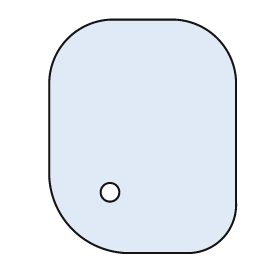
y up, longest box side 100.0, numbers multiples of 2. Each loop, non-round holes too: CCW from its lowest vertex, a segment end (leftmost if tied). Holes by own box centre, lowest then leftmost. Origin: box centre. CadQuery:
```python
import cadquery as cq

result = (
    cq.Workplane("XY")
    .moveTo(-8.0, -50.0)
    .lineTo(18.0, -50.0)
    .threePointArc((34.0, -44.0), (40.0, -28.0))
    .lineTo(40.0, 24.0)
    .threePointArc((32.0, 42.0), (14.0, 50.0))
    .lineTo(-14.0, 50.0)
    .threePointArc((-32.0, 42.0), (-40.0, 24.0))
    .lineTo(-40.0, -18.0)
    .threePointArc((-30.0, -40.0), (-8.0, -50.0))
    .close()
    .moveTo(-14.0, -24.0)
    .circle(4.0)
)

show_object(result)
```